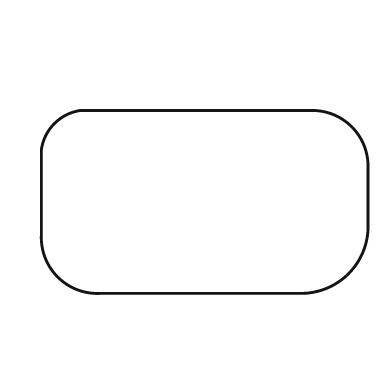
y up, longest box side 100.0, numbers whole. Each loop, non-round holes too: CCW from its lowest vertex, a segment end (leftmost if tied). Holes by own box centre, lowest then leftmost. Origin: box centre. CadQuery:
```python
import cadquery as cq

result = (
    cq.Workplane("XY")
    .moveTo(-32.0, -28.0)
    .lineTo(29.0, -28.0)
    .threePointArc((44.0, -22.0), (50.0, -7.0))
    .lineTo(50.0, 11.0)
    .threePointArc((45.0, 23.0), (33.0, 28.0))
    .lineTo(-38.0, 28.0)
    .threePointArc((-46.0, 24.0), (-50.0, 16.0))
    .lineTo(-50.0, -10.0)
    .threePointArc((-45.0, -23.0), (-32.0, -28.0))
    .close()
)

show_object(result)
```